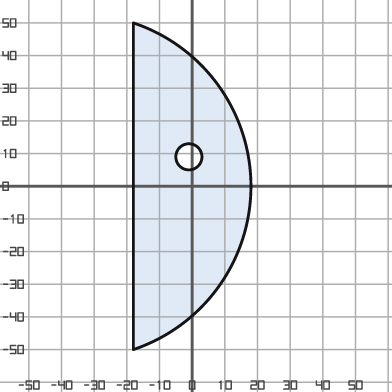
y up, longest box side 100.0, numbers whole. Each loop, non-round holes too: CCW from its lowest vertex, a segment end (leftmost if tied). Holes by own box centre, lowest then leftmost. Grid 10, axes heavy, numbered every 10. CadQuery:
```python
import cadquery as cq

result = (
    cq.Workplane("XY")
    .moveTo(-18.0, -50.0)
    .threePointArc((18.0, 0.0), (-18.0, 50.0))
    .close()
    .moveTo(-1.0, 9.0)
    .circle(4.0)
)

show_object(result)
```